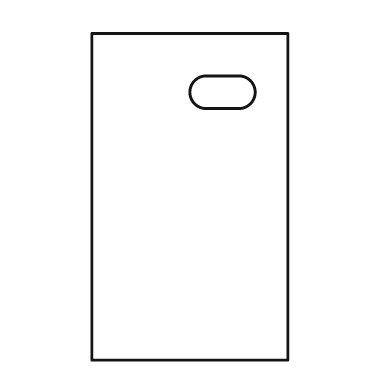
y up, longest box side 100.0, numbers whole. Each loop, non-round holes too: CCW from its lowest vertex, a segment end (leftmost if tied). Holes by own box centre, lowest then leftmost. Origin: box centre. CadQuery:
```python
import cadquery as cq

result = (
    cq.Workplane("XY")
    .moveTo(-30.0, -50.0)
    .lineTo(30.0, -50.0)
    .lineTo(30.0, 50.0)
    .lineTo(-30.0, 50.0)
    .close()
    .moveTo(5.0, 27.0)
    .lineTo(15.0, 27.0)
    .threePointArc((20.0, 32.0), (15.0, 37.0))
    .lineTo(5.0, 37.0)
    .threePointArc((0.0, 32.0), (5.0, 27.0))
    .close()
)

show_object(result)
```